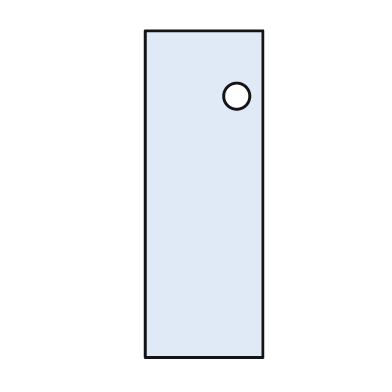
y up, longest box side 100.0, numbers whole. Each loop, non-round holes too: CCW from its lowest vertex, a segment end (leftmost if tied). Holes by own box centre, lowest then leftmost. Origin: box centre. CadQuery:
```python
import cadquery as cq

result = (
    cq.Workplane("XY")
    .moveTo(-18.0, -50.0)
    .lineTo(18.0, -50.0)
    .lineTo(18.0, 50.0)
    .lineTo(-18.0, 50.0)
    .close()
    .moveTo(10.0, 30.0)
    .circle(4.0)
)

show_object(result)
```